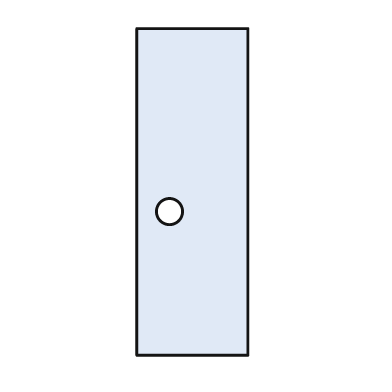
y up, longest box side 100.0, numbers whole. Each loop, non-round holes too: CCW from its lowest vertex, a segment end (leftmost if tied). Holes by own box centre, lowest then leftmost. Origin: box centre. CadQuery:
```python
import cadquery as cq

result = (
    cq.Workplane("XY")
    .moveTo(-17.0, -50.0)
    .lineTo(17.0, -50.0)
    .lineTo(17.0, 50.0)
    .lineTo(-17.0, 50.0)
    .close()
    .moveTo(-7.0, -6.0)
    .circle(4.0)
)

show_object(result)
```